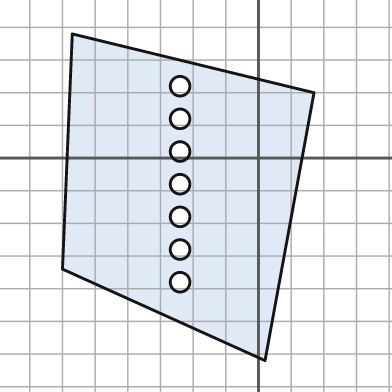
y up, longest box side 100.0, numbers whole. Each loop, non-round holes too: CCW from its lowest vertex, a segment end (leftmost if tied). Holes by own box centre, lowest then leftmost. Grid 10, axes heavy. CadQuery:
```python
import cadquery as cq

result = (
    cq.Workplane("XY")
    .moveTo(2.0, -62.0)
    .lineTo(17.0, 20.0)
    .lineTo(-57.0, 38.0)
    .lineTo(-60.0, -34.0)
    .close()
    .moveTo(-24.0, -38.0)
    .circle(3.0)
    .moveTo(-24.0, -28.0)
    .circle(3.0)
    .moveTo(-24.0, -18.0)
    .circle(3.0)
    .moveTo(-24.0, -8.0)
    .circle(3.0)
    .moveTo(-24.0, 2.0)
    .circle(3.0)
    .moveTo(-24.0, 12.0)
    .circle(3.0)
    .moveTo(-24.0, 22.0)
    .circle(3.0)
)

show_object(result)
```